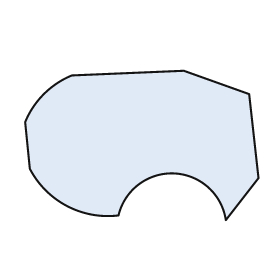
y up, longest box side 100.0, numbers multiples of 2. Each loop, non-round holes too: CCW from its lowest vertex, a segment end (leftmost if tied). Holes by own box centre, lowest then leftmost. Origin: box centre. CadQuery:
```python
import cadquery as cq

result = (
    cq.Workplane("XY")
    .moveTo(36.0, -32.0)
    .lineTo(50.0, -14.0)
    .lineTo(46.0, 22.0)
    .lineTo(18.0, 32.0)
    .lineTo(-30.0, 30.0)
    .threePointArc((-42.0, 22.0), (-50.0, 10.0))
    .lineTo(-48.0, -10.0)
    .threePointArc((-32.0, -26.0), (-10.0, -30.0))
    .threePointArc((14.0, -12.0), (36.0, -32.0))
    .close()
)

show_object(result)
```